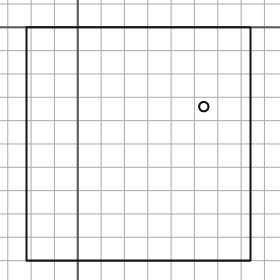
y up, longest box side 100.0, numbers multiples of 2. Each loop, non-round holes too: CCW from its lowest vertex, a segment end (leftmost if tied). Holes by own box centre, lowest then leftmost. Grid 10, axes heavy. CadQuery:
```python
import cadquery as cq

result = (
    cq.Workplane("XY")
    .moveTo(-22.0, -100.0)
    .lineTo(74.0, -100.0)
    .lineTo(74.0, 0.0)
    .lineTo(-22.0, 0.0)
    .close()
    .moveTo(54.0, -34.0)
    .circle(2.0)
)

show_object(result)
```